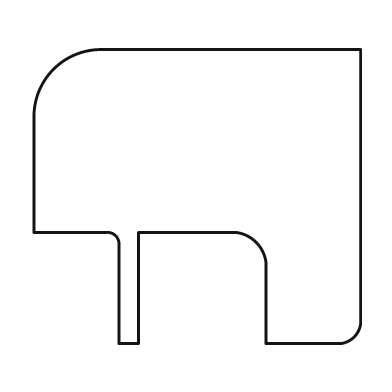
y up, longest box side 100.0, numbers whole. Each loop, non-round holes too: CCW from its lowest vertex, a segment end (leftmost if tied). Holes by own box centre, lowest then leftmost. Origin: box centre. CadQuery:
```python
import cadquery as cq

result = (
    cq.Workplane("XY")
    .moveTo(-24.0, -45.0)
    .lineTo(-18.0, -45.0)
    .lineTo(-18.0, -11.0)
    .lineTo(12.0, -11.0)
    .threePointArc((18.0, -14.0), (21.0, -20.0))
    .lineTo(21.0, -45.0)
    .lineTo(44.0, -45.0)
    .threePointArc((48.0, -43.0), (50.0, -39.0))
    .lineTo(50.0, 45.0)
    .lineTo(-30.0, 45.0)
    .threePointArc((-44.0, 39.0), (-50.0, 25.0))
    .lineTo(-50.0, -11.0)
    .lineTo(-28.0, -11.0)
    .threePointArc((-25.0, -12.0), (-24.0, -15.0))
    .close()
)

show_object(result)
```